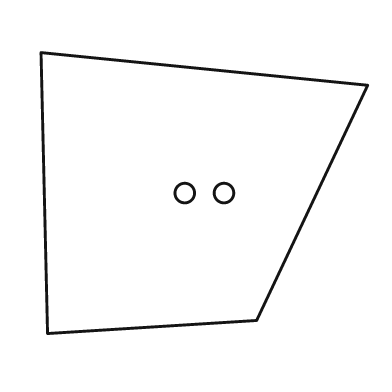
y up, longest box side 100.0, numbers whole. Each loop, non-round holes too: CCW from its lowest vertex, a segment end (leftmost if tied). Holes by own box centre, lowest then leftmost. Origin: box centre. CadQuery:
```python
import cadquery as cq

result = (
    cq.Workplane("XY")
    .moveTo(-48.0, -43.0)
    .lineTo(16.0, -39.0)
    .lineTo(50.0, 33.0)
    .lineTo(-50.0, 43.0)
    .close()
    .moveTo(-6.0, 0.0)
    .circle(3.0)
    .moveTo(6.0, 0.0)
    .circle(3.0)
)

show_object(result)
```